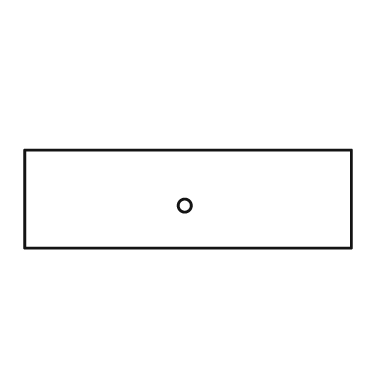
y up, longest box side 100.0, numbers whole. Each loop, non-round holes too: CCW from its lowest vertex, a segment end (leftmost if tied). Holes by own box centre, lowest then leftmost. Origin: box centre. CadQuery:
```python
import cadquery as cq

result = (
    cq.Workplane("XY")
    .moveTo(-50.0, -15.0)
    .lineTo(50.0, -15.0)
    .lineTo(50.0, 15.0)
    .lineTo(-50.0, 15.0)
    .close()
    .moveTo(-1.0, -2.0)
    .circle(2.0)
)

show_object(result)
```